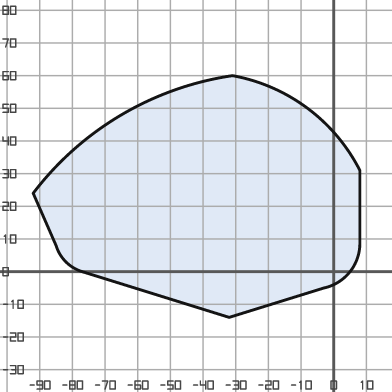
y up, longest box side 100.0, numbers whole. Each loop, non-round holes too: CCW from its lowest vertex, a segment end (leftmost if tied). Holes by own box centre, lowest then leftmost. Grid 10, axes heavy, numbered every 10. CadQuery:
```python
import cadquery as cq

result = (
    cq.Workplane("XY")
    .moveTo(-32.0, -14.0)
    .lineTo(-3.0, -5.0)
    .threePointArc((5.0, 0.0), (8.0, 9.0))
    .lineTo(8.0, 31.0)
    .threePointArc((-8.0, 50.0), (-31.0, 60.0))
    .threePointArc((-65.0, 48.0), (-92.0, 24.0))
    .lineTo(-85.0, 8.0)
    .threePointArc((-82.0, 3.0), (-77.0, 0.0))
    .close()
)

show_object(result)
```